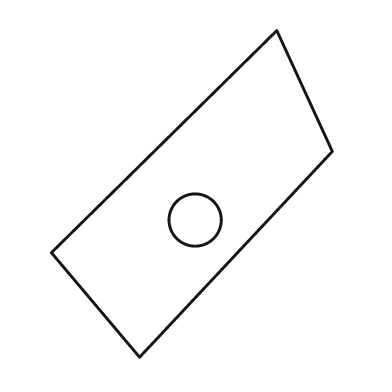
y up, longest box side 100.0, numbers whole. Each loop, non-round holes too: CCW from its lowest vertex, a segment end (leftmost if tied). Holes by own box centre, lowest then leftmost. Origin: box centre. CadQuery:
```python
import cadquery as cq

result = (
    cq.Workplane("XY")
    .moveTo(-16.0, -50.0)
    .lineTo(43.0, 13.0)
    .lineTo(26.0, 50.0)
    .lineTo(-43.0, -18.0)
    .close()
    .moveTo(1.0, -8.0)
    .circle(8.0)
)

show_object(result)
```